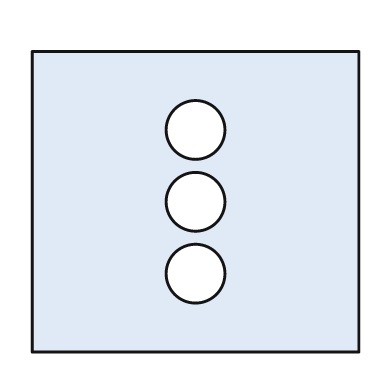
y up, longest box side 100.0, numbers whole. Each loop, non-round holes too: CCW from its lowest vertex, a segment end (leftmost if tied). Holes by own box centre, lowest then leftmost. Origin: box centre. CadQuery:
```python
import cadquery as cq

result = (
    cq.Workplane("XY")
    .moveTo(-50.0, -46.0)
    .lineTo(50.0, -46.0)
    .lineTo(50.0, 46.0)
    .lineTo(-50.0, 46.0)
    .close()
    .moveTo(0.0, -22.0)
    .circle(9.0)
    .moveTo(0.0, 0.0)
    .circle(9.0)
    .moveTo(0.0, 22.0)
    .circle(9.0)
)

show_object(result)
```